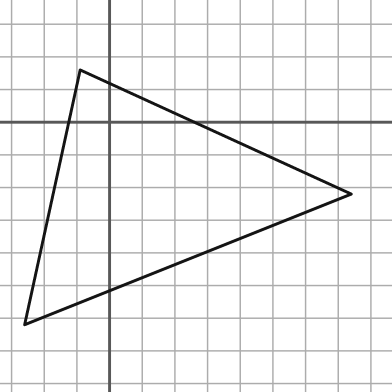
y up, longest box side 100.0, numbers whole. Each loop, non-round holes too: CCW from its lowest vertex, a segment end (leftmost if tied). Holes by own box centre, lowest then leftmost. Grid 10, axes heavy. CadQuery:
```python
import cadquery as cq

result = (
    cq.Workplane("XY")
    .moveTo(-26.0, -62.0)
    .lineTo(74.0, -22.0)
    .lineTo(-9.0, 16.0)
    .close()
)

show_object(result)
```